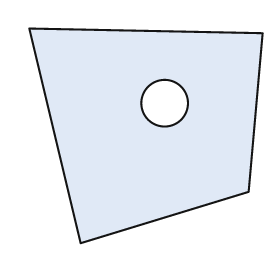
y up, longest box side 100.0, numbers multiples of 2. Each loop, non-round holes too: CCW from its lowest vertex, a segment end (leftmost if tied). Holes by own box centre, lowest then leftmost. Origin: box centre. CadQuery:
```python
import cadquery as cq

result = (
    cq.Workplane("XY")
    .moveTo(-28.0, -46.0)
    .lineTo(44.0, -24.0)
    .lineTo(50.0, 44.0)
    .lineTo(-50.0, 46.0)
    .close()
    .moveTo(8.0, 14.0)
    .circle(10.0)
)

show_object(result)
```